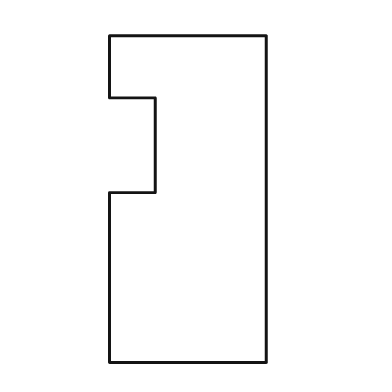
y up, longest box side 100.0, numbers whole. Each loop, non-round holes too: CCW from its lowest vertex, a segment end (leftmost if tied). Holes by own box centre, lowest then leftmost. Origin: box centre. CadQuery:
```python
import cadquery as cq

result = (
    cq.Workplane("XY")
    .moveTo(-24.0, -50.0)
    .lineTo(24.0, -50.0)
    .lineTo(24.0, 50.0)
    .lineTo(-24.0, 50.0)
    .lineTo(-24.0, 31.0)
    .lineTo(-10.0, 31.0)
    .lineTo(-10.0, 2.0)
    .lineTo(-24.0, 2.0)
    .close()
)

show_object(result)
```